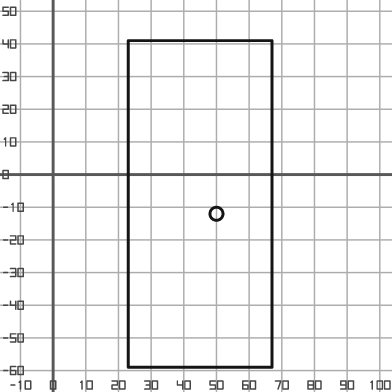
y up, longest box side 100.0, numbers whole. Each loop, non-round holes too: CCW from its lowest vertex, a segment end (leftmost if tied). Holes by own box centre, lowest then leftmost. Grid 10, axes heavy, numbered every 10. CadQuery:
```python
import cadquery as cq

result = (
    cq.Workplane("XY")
    .moveTo(23.0, -59.0)
    .lineTo(67.0, -59.0)
    .lineTo(67.0, 41.0)
    .lineTo(23.0, 41.0)
    .close()
    .moveTo(50.0, -12.0)
    .circle(2.0)
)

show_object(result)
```